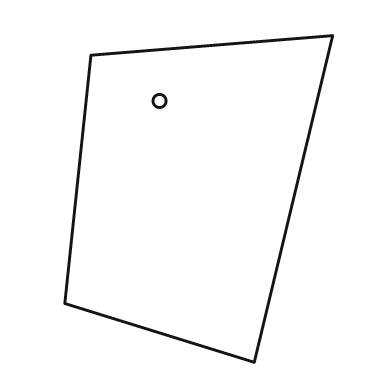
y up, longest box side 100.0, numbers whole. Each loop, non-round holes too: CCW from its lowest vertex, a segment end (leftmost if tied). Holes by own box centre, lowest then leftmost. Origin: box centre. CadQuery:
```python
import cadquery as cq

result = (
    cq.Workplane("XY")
    .moveTo(17.0, -50.0)
    .lineTo(41.0, 50.0)
    .lineTo(-33.0, 44.0)
    .lineTo(-41.0, -32.0)
    .close()
    .moveTo(-12.0, 30.0)
    .circle(2.0)
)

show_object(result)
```